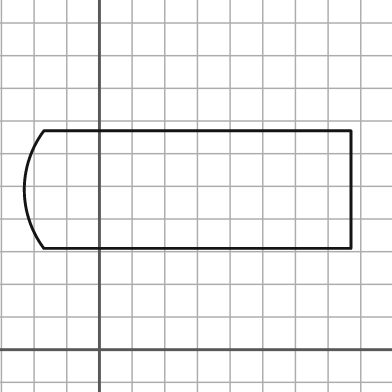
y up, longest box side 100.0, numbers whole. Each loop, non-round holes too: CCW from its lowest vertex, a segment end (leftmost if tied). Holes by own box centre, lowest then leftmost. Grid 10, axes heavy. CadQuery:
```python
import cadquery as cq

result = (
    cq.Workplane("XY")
    .moveTo(-17.0, 31.0)
    .lineTo(77.0, 31.0)
    .lineTo(77.0, 67.0)
    .lineTo(-17.0, 67.0)
    .threePointArc((-23.0, 49.0), (-17.0, 31.0))
    .close()
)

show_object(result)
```